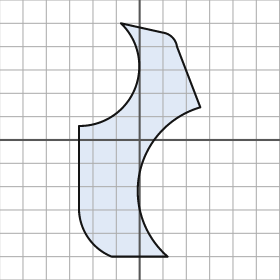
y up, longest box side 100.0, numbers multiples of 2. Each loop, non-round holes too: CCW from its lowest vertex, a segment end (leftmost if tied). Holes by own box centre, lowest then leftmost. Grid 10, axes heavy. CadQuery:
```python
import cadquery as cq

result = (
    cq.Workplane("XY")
    .moveTo(-12.0, -50.0)
    .lineTo(12.0, -50.0)
    .threePointArc((0.0, -14.0), (26.0, 14.0))
    .lineTo(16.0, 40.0)
    .threePointArc((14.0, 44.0), (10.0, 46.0))
    .lineTo(-8.0, 50.0)
    .threePointArc((-2.0, 22.0), (-26.0, 6.0))
    .lineTo(-26.0, -30.0)
    .threePointArc((-22.0, -42.0), (-12.0, -50.0))
    .close()
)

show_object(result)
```